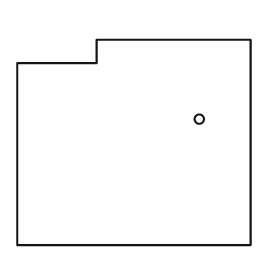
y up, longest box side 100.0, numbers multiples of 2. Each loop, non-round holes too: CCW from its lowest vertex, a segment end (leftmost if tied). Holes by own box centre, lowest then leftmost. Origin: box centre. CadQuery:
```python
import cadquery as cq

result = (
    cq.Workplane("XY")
    .moveTo(-50.0, -44.0)
    .lineTo(50.0, -44.0)
    .lineTo(50.0, 44.0)
    .lineTo(-16.0, 44.0)
    .lineTo(-16.0, 34.0)
    .lineTo(-50.0, 34.0)
    .close()
    .moveTo(28.0, 10.0)
    .circle(2.0)
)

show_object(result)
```